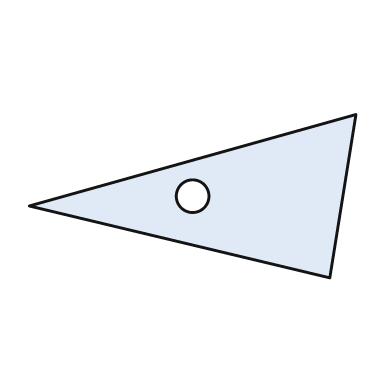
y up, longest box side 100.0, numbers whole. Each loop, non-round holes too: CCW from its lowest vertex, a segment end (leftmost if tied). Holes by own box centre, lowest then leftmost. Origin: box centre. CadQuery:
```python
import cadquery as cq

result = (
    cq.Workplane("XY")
    .moveTo(42.0, -25.0)
    .lineTo(50.0, 25.0)
    .lineTo(-50.0, -3.0)
    .close()
    .moveTo(0.0, 0.0)
    .circle(5.0)
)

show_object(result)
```